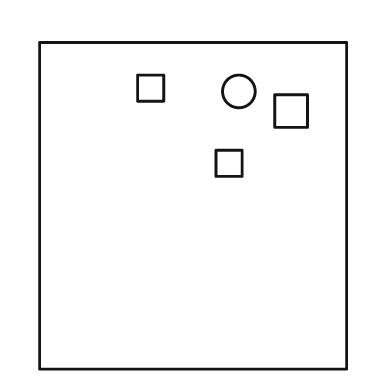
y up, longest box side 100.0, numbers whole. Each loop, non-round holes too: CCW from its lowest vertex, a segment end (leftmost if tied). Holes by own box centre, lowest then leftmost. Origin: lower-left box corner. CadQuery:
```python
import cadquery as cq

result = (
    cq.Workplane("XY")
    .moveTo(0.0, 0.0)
    .lineTo(94.0, 0.0)
    .lineTo(94.0, 100.0)
    .lineTo(0.0, 100.0)
    .close()
    .moveTo(54.0, 59.0)
    .lineTo(62.0, 59.0)
    .lineTo(62.0, 67.0)
    .lineTo(54.0, 67.0)
    .close()
    .moveTo(72.0, 74.0)
    .lineTo(82.0, 74.0)
    .lineTo(82.0, 84.0)
    .lineTo(72.0, 84.0)
    .close()
    .moveTo(61.0, 85.0)
    .circle(5.0)
    .moveTo(30.0, 82.0)
    .lineTo(38.0, 82.0)
    .lineTo(38.0, 90.0)
    .lineTo(30.0, 90.0)
    .close()
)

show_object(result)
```